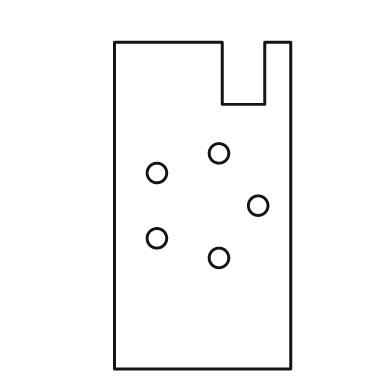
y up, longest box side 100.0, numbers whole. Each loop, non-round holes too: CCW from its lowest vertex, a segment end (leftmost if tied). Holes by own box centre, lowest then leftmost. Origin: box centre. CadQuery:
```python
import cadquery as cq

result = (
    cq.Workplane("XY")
    .moveTo(-27.0, -50.0)
    .lineTo(27.0, -50.0)
    .lineTo(27.0, 50.0)
    .lineTo(19.0, 50.0)
    .lineTo(19.0, 31.0)
    .lineTo(6.0, 31.0)
    .lineTo(6.0, 50.0)
    .lineTo(-27.0, 50.0)
    .close()
    .moveTo(5.0, -16.0)
    .circle(3.0)
    .moveTo(-14.0, -10.0)
    .circle(3.0)
    .moveTo(17.0, 0.0)
    .circle(3.0)
    .moveTo(-14.0, 10.0)
    .circle(3.0)
    .moveTo(5.0, 16.0)
    .circle(3.0)
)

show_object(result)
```